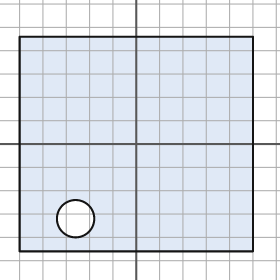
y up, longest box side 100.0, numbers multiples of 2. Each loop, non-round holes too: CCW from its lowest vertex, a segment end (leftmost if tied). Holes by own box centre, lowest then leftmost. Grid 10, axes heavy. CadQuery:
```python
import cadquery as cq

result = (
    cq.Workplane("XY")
    .moveTo(-50.0, -46.0)
    .lineTo(50.0, -46.0)
    .lineTo(50.0, 46.0)
    .lineTo(-50.0, 46.0)
    .close()
    .moveTo(-26.0, -32.0)
    .circle(8.0)
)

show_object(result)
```